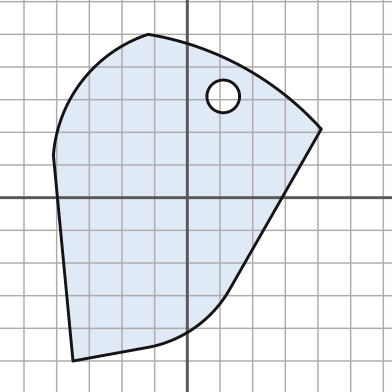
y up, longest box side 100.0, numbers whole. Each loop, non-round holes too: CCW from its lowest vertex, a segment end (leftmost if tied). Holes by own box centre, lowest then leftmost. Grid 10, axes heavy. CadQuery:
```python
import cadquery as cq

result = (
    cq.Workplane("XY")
    .moveTo(-35.0, -50.0)
    .lineTo(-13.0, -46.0)
    .threePointArc((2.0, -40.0), (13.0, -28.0))
    .lineTo(41.0, 21.0)
    .threePointArc((17.0, 40.0), (-12.0, 50.0))
    .threePointArc((-32.0, 36.0), (-41.0, 13.0))
    .close()
    .moveTo(11.0, 31.0)
    .circle(5.0)
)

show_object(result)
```